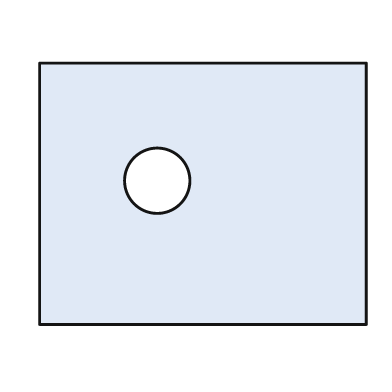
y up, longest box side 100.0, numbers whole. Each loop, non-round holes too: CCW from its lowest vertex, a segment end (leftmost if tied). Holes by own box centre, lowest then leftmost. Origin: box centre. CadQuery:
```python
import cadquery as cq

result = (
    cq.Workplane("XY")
    .moveTo(-50.0, -40.0)
    .lineTo(50.0, -40.0)
    .lineTo(50.0, 40.0)
    .lineTo(-50.0, 40.0)
    .close()
    .moveTo(-14.0, 4.0)
    .circle(10.0)
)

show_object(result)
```